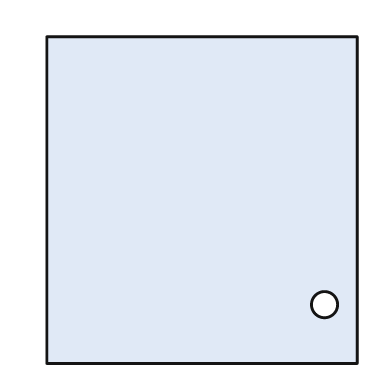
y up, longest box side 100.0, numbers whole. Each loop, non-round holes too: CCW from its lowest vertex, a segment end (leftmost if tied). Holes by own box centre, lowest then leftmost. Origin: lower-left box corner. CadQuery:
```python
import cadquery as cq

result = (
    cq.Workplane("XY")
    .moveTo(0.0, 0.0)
    .lineTo(95.0, 0.0)
    .lineTo(95.0, 100.0)
    .lineTo(0.0, 100.0)
    .close()
    .moveTo(85.0, 18.0)
    .circle(4.0)
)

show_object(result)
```